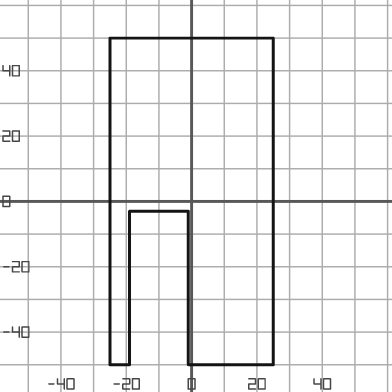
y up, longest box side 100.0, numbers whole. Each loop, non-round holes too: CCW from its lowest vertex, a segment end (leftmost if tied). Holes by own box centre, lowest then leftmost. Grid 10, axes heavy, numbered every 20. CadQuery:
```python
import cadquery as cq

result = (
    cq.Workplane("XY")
    .moveTo(-25.0, -50.0)
    .lineTo(-19.0, -50.0)
    .lineTo(-19.0, -3.0)
    .lineTo(-1.0, -3.0)
    .lineTo(-1.0, -50.0)
    .lineTo(25.0, -50.0)
    .lineTo(25.0, 50.0)
    .lineTo(-25.0, 50.0)
    .close()
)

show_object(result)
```